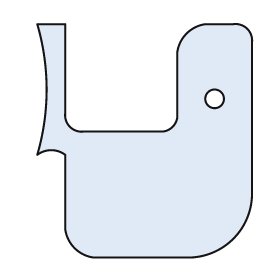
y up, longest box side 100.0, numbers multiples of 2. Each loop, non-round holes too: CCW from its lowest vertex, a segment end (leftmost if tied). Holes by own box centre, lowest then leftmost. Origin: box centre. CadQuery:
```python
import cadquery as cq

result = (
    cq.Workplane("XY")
    .moveTo(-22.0, -50.0)
    .lineTo(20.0, -50.0)
    .threePointArc((38.0, -42.0), (46.0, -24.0))
    .lineTo(46.0, 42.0)
    .threePointArc((44.0, 48.0), (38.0, 50.0))
    .lineTo(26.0, 50.0)
    .threePointArc((18.0, 46.0), (14.0, 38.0))
    .lineTo(14.0, 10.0)
    .threePointArc((12.0, 6.0), (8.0, 4.0))
    .lineTo(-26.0, 4.0)
    .threePointArc((-32.0, 6.0), (-34.0, 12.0))
    .lineTo(-34.0, 50.0)
    .lineTo(-46.0, 50.0)
    .threePointArc((-42.0, 22.0), (-46.0, -6.0))
    .threePointArc((-40.0, -4.0), (-34.0, -6.0))
    .lineTo(-34.0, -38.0)
    .threePointArc((-30.0, -46.0), (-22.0, -50.0))
    .close()
    .moveTo(30.0, 18.0)
    .circle(4.0)
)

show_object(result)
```